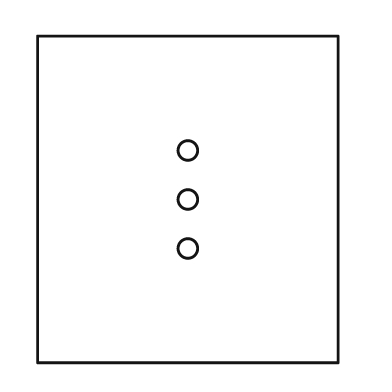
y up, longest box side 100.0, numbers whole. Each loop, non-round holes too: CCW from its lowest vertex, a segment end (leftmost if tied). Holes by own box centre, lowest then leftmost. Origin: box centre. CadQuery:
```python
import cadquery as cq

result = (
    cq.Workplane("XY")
    .moveTo(-46.0, -50.0)
    .lineTo(46.0, -50.0)
    .lineTo(46.0, 50.0)
    .lineTo(-46.0, 50.0)
    .close()
    .moveTo(0.0, -15.0)
    .circle(3.0)
    .moveTo(0.0, 0.0)
    .circle(3.0)
    .moveTo(0.0, 15.0)
    .circle(3.0)
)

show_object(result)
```